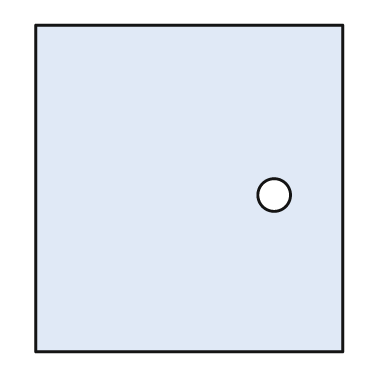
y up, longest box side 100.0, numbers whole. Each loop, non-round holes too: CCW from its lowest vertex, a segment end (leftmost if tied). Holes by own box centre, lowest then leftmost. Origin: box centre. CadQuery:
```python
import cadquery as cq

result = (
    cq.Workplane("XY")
    .moveTo(-47.0, -50.0)
    .lineTo(47.0, -50.0)
    .lineTo(47.0, 50.0)
    .lineTo(-47.0, 50.0)
    .close()
    .moveTo(26.0, -2.0)
    .circle(5.0)
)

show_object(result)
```